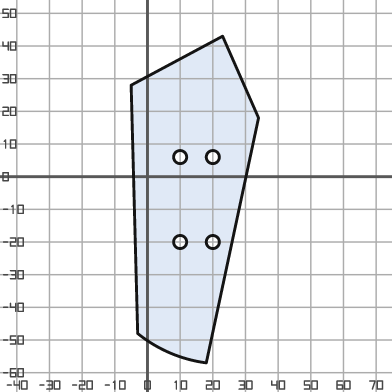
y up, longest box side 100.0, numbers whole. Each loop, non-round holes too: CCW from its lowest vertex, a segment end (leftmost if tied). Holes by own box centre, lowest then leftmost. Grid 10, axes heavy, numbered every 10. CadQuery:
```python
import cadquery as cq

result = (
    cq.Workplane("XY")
    .moveTo(18.0, -57.0)
    .lineTo(34.0, 18.0)
    .lineTo(23.0, 43.0)
    .lineTo(-5.0, 28.0)
    .lineTo(-3.0, -48.0)
    .threePointArc((7.0, -54.0), (18.0, -57.0))
    .close()
    .moveTo(10.0, -20.0)
    .circle(2.0)
    .moveTo(20.0, -20.0)
    .circle(2.0)
    .moveTo(10.0, 6.0)
    .circle(2.0)
    .moveTo(20.0, 6.0)
    .circle(2.0)
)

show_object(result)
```